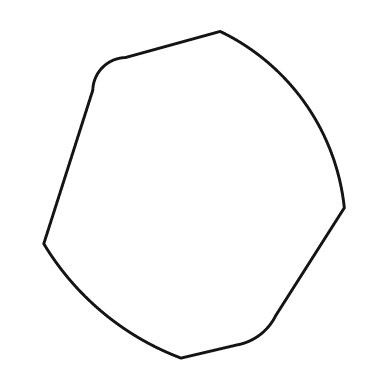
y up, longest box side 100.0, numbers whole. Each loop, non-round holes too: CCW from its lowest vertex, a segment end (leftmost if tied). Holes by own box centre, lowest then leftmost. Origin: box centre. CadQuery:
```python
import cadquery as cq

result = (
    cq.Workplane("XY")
    .moveTo(-4.0, -50.0)
    .lineTo(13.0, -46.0)
    .threePointArc((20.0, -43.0), (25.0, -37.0))
    .lineTo(46.0, -4.0)
    .threePointArc((34.0, 28.0), (8.0, 50.0))
    .lineTo(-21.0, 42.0)
    .threePointArc((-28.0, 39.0), (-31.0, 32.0))
    .lineTo(-46.0, -15.0)
    .threePointArc((-28.0, -36.0), (-4.0, -50.0))
    .close()
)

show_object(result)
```